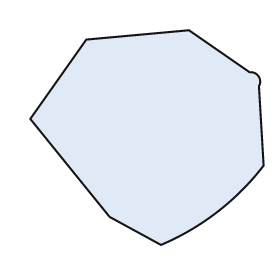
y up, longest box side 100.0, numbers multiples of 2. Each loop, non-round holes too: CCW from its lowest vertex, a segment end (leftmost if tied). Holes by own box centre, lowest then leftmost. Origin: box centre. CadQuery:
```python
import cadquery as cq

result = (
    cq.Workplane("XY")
    .moveTo(6.0, -46.0)
    .threePointArc((30.0, -32.0), (50.0, -12.0))
    .lineTo(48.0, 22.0)
    .threePointArc((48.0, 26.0), (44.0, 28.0))
    .lineTo(18.0, 46.0)
    .lineTo(-26.0, 42.0)
    .lineTo(-50.0, 8.0)
    .lineTo(-16.0, -34.0)
    .close()
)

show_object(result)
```